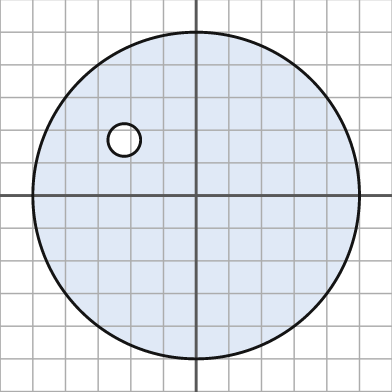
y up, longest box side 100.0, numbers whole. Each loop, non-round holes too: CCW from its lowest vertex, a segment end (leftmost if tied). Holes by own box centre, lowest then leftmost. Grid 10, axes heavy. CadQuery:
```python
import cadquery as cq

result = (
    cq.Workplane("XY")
    .moveTo(0.0, 0.0)
    .circle(50.0)
    .moveTo(-22.0, 17.0)
    .circle(5.0)
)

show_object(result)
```